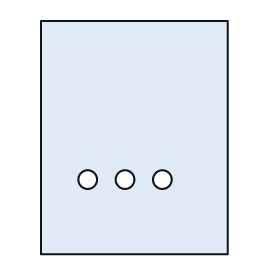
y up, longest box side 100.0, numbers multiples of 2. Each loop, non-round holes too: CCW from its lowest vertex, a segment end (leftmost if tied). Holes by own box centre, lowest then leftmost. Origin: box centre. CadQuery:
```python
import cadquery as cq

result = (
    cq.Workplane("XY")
    .moveTo(-40.0, -50.0)
    .lineTo(40.0, -50.0)
    .lineTo(40.0, 50.0)
    .lineTo(-40.0, 50.0)
    .close()
    .moveTo(-20.0, -18.0)
    .circle(4.0)
    .moveTo(-4.0, -18.0)
    .circle(4.0)
    .moveTo(12.0, -18.0)
    .circle(4.0)
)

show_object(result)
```